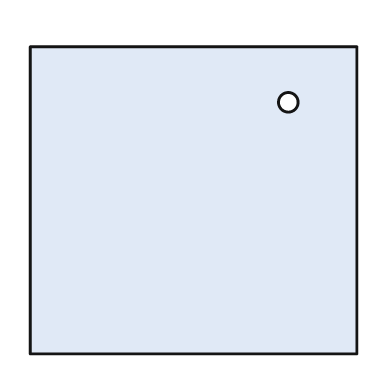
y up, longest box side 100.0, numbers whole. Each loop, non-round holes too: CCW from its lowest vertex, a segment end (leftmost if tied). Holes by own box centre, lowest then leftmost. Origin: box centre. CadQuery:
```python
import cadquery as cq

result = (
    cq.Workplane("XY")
    .moveTo(-50.0, -47.0)
    .lineTo(50.0, -47.0)
    .lineTo(50.0, 47.0)
    .lineTo(-50.0, 47.0)
    .close()
    .moveTo(29.0, 30.0)
    .circle(3.0)
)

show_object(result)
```